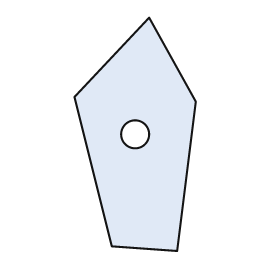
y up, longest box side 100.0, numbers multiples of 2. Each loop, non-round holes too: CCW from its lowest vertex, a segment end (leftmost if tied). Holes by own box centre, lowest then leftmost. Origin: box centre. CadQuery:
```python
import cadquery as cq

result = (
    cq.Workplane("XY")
    .moveTo(18.0, -50.0)
    .lineTo(26.0, 14.0)
    .lineTo(6.0, 50.0)
    .lineTo(-26.0, 16.0)
    .lineTo(-10.0, -48.0)
    .close()
    .moveTo(0.0, 0.0)
    .circle(6.0)
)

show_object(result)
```